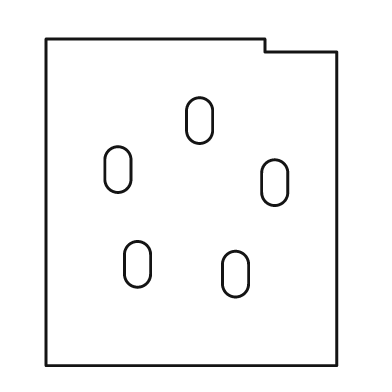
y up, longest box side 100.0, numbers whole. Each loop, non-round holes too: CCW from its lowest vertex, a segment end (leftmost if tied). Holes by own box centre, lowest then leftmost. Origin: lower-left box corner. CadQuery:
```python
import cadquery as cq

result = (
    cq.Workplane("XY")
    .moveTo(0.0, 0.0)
    .lineTo(89.0, 0.0)
    .lineTo(89.0, 96.0)
    .lineTo(67.0, 96.0)
    .lineTo(67.0, 100.0)
    .lineTo(0.0, 100.0)
    .close()
    .moveTo(54.0, 25.0)
    .threePointArc((58.0, 21.0), (62.0, 25.0))
    .lineTo(62.0, 31.0)
    .threePointArc((58.0, 35.0), (54.0, 31.0))
    .close()
    .moveTo(24.0, 28.0)
    .threePointArc((28.0, 24.0), (32.0, 28.0))
    .lineTo(32.0, 34.0)
    .threePointArc((28.0, 38.0), (24.0, 34.0))
    .close()
    .moveTo(66.0, 53.0)
    .threePointArc((70.0, 49.0), (74.0, 53.0))
    .lineTo(74.0, 59.0)
    .threePointArc((70.0, 63.0), (66.0, 59.0))
    .close()
    .moveTo(18.0, 57.0)
    .threePointArc((22.0, 53.0), (26.0, 57.0))
    .lineTo(26.0, 63.0)
    .threePointArc((22.0, 67.0), (18.0, 63.0))
    .close()
    .moveTo(43.0, 72.0)
    .threePointArc((47.0, 68.0), (51.0, 72.0))
    .lineTo(51.0, 78.0)
    .threePointArc((47.0, 82.0), (43.0, 78.0))
    .close()
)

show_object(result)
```